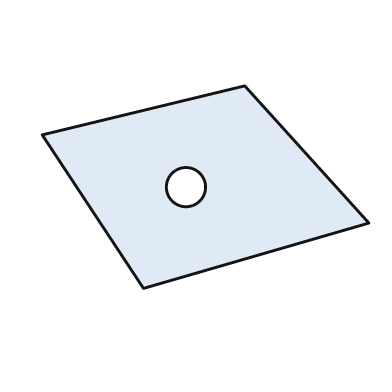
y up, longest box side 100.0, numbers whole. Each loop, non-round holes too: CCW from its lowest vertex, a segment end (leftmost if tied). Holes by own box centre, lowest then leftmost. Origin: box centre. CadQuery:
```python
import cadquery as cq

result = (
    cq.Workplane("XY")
    .moveTo(-19.0, -31.0)
    .lineTo(50.0, -11.0)
    .lineTo(12.0, 31.0)
    .lineTo(-50.0, 16.0)
    .close()
    .moveTo(-6.0, 0.0)
    .circle(6.0)
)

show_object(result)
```